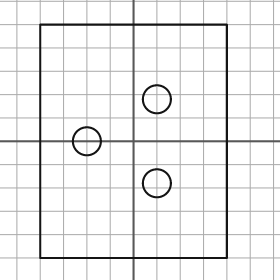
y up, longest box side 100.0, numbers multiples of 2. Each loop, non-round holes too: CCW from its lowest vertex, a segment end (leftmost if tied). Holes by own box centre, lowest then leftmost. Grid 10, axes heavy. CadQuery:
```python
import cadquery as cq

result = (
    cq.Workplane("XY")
    .moveTo(-40.0, -50.0)
    .lineTo(40.0, -50.0)
    .lineTo(40.0, 50.0)
    .lineTo(-40.0, 50.0)
    .close()
    .moveTo(10.0, -18.0)
    .circle(6.0)
    .moveTo(-20.0, 0.0)
    .circle(6.0)
    .moveTo(10.0, 18.0)
    .circle(6.0)
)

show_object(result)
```